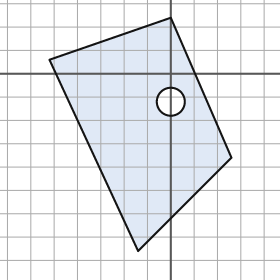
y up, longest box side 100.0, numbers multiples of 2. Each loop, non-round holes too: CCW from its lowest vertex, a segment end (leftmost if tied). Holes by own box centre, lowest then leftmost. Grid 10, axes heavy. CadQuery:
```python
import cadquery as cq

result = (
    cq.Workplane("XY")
    .moveTo(-14.0, -76.0)
    .lineTo(26.0, -36.0)
    .lineTo(0.0, 24.0)
    .lineTo(-52.0, 6.0)
    .close()
    .moveTo(0.0, -12.0)
    .circle(6.0)
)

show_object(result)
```